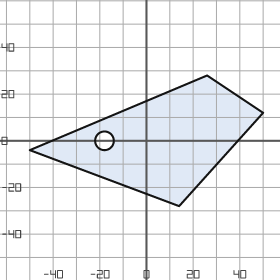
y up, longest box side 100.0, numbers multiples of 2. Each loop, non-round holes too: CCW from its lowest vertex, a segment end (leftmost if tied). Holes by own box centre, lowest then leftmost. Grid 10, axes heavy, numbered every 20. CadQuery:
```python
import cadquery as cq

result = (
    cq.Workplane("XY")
    .moveTo(14.0, -28.0)
    .lineTo(50.0, 12.0)
    .lineTo(26.0, 28.0)
    .lineTo(-50.0, -4.0)
    .close()
    .moveTo(-18.0, 0.0)
    .circle(4.0)
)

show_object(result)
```